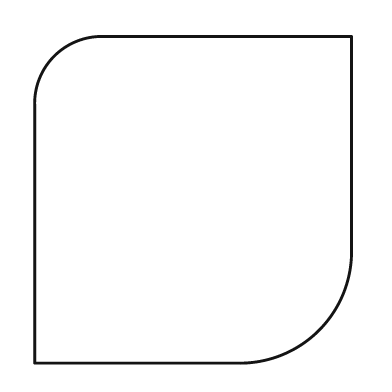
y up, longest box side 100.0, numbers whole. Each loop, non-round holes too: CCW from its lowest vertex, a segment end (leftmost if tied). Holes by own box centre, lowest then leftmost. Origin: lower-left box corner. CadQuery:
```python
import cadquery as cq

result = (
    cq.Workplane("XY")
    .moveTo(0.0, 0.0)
    .lineTo(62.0, 0.0)
    .threePointArc((87.0, 10.0), (97.0, 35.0))
    .lineTo(97.0, 100.0)
    .lineTo(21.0, 100.0)
    .threePointArc((6.0, 94.0), (0.0, 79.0))
    .close()
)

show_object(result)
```